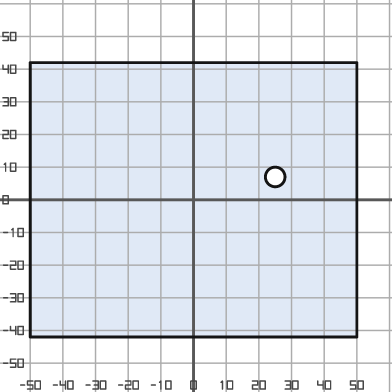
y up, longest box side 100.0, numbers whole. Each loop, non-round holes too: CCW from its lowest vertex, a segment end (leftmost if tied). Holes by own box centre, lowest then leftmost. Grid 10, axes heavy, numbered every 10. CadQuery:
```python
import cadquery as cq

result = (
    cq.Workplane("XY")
    .moveTo(-50.0, -42.0)
    .lineTo(50.0, -42.0)
    .lineTo(50.0, 42.0)
    .lineTo(-50.0, 42.0)
    .close()
    .moveTo(25.0, 7.0)
    .circle(3.0)
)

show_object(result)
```